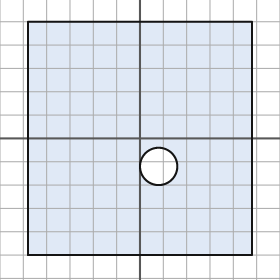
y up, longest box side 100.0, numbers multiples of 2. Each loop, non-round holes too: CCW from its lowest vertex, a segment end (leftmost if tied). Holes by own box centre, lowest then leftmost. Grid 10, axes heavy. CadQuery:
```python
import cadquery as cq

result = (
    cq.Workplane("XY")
    .moveTo(-48.0, -50.0)
    .lineTo(48.0, -50.0)
    .lineTo(48.0, 50.0)
    .lineTo(-48.0, 50.0)
    .close()
    .moveTo(8.0, -12.0)
    .circle(8.0)
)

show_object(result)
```